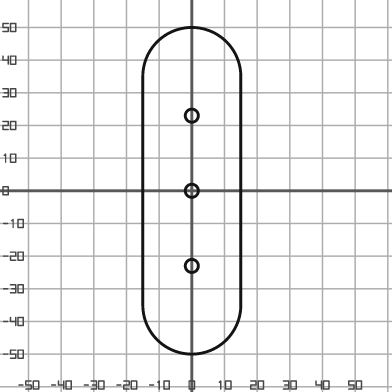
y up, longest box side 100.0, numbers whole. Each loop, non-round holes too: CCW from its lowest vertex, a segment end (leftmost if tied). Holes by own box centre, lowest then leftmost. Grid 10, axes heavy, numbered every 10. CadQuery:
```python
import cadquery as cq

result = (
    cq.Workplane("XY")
    .moveTo(-15.0, -35.0)
    .threePointArc((0.0, -50.0), (15.0, -35.0))
    .lineTo(15.0, 35.0)
    .threePointArc((0.0, 50.0), (-15.0, 35.0))
    .close()
    .moveTo(0.0, -23.0)
    .circle(2.0)
    .moveTo(0.0, 0.0)
    .circle(2.0)
    .moveTo(0.0, 23.0)
    .circle(2.0)
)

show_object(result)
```